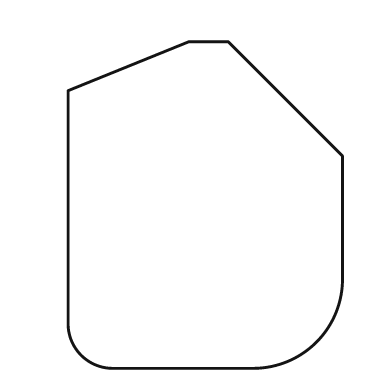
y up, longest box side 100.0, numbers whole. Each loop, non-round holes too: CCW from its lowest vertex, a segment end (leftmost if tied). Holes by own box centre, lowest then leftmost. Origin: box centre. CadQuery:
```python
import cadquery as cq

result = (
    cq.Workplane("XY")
    .moveTo(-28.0, -50.0)
    .lineTo(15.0, -50.0)
    .threePointArc((34.0, -42.0), (42.0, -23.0))
    .lineTo(42.0, 15.0)
    .lineTo(7.0, 50.0)
    .lineTo(-5.0, 50.0)
    .lineTo(-42.0, 35.0)
    .lineTo(-42.0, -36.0)
    .threePointArc((-38.0, -46.0), (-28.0, -50.0))
    .close()
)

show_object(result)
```